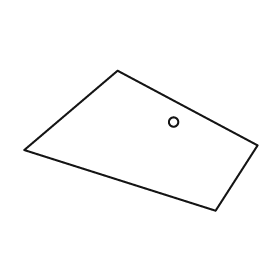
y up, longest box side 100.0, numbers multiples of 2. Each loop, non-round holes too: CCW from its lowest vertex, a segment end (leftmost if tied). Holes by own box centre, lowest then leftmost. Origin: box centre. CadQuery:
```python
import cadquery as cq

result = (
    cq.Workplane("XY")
    .moveTo(32.0, -30.0)
    .lineTo(50.0, -2.0)
    .lineTo(-10.0, 30.0)
    .lineTo(-50.0, -4.0)
    .close()
    .moveTo(14.0, 8.0)
    .circle(2.0)
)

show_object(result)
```